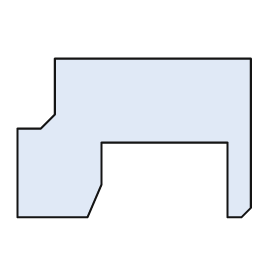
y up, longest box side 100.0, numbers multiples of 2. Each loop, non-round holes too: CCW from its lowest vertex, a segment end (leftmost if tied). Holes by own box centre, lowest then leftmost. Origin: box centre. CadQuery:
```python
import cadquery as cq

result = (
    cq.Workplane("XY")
    .moveTo(-50.0, -34.0)
    .lineTo(-20.0, -34.0)
    .lineTo(-14.0, -20.0)
    .lineTo(-14.0, -2.0)
    .lineTo(40.0, -2.0)
    .lineTo(40.0, -34.0)
    .lineTo(46.0, -34.0)
    .lineTo(50.0, -30.0)
    .lineTo(50.0, 34.0)
    .lineTo(-34.0, 34.0)
    .lineTo(-34.0, 10.0)
    .lineTo(-40.0, 4.0)
    .lineTo(-50.0, 4.0)
    .close()
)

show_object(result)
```